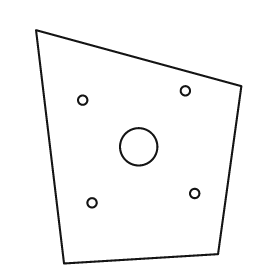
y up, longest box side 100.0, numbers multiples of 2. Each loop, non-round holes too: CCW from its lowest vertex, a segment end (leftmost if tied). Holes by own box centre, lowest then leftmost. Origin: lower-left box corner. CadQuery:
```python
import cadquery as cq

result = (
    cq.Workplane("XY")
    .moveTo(12.0, 0.0)
    .lineTo(78.0, 4.0)
    .lineTo(88.0, 76.0)
    .lineTo(0.0, 100.0)
    .close()
    .moveTo(24.0, 26.0)
    .circle(2.0)
    .moveTo(68.0, 30.0)
    .circle(2.0)
    .moveTo(44.0, 50.0)
    .circle(8.0)
    .moveTo(20.0, 70.0)
    .circle(2.0)
    .moveTo(64.0, 74.0)
    .circle(2.0)
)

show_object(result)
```